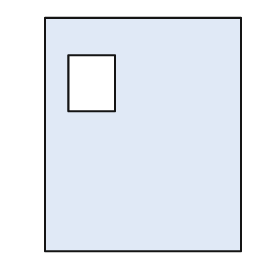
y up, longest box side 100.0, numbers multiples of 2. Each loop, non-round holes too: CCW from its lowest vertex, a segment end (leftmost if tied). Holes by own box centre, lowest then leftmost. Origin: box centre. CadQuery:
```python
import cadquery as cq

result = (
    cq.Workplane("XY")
    .moveTo(-42.0, -50.0)
    .lineTo(42.0, -50.0)
    .lineTo(42.0, 50.0)
    .lineTo(-42.0, 50.0)
    .close()
    .moveTo(-32.0, 10.0)
    .lineTo(-12.0, 10.0)
    .lineTo(-12.0, 34.0)
    .lineTo(-32.0, 34.0)
    .close()
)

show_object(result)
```